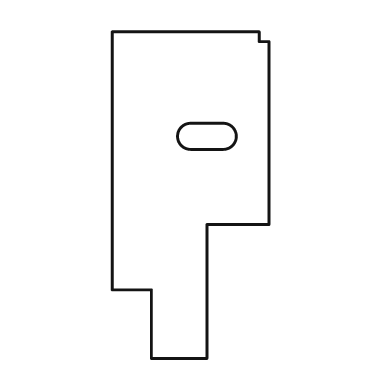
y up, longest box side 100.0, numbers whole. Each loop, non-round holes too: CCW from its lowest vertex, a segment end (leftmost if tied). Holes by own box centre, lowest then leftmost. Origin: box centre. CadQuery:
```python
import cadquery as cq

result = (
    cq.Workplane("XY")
    .moveTo(-12.0, -50.0)
    .lineTo(5.0, -50.0)
    .lineTo(5.0, -9.0)
    .lineTo(24.0, -9.0)
    .lineTo(24.0, 47.0)
    .lineTo(21.0, 47.0)
    .lineTo(21.0, 50.0)
    .lineTo(-24.0, 50.0)
    .lineTo(-24.0, -29.0)
    .lineTo(-12.0, -29.0)
    .close()
    .moveTo(0.0, 14.0)
    .lineTo(10.0, 14.0)
    .threePointArc((14.0, 18.0), (10.0, 22.0))
    .lineTo(0.0, 22.0)
    .threePointArc((-4.0, 18.0), (0.0, 14.0))
    .close()
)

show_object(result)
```